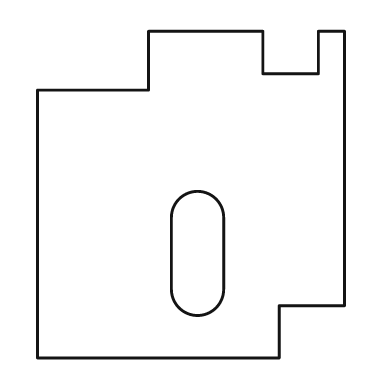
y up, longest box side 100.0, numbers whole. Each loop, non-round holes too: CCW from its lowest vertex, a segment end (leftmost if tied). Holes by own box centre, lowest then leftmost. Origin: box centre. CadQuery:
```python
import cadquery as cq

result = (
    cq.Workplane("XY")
    .moveTo(-47.0, -50.0)
    .lineTo(27.0, -50.0)
    .lineTo(27.0, -34.0)
    .lineTo(47.0, -34.0)
    .lineTo(47.0, 50.0)
    .lineTo(39.0, 50.0)
    .lineTo(39.0, 37.0)
    .lineTo(22.0, 37.0)
    .lineTo(22.0, 50.0)
    .lineTo(-13.0, 50.0)
    .lineTo(-13.0, 32.0)
    .lineTo(-47.0, 32.0)
    .close()
    .moveTo(-6.0, -29.0)
    .threePointArc((2.0, -37.0), (10.0, -29.0))
    .lineTo(10.0, -7.0)
    .threePointArc((2.0, 1.0), (-6.0, -7.0))
    .close()
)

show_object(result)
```